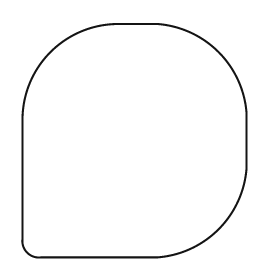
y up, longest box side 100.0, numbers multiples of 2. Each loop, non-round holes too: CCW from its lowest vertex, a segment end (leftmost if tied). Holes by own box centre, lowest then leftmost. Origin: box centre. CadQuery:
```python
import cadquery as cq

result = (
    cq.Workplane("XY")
    .moveTo(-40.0, -50.0)
    .lineTo(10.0, -50.0)
    .threePointArc((36.0, -38.0), (48.0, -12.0))
    .lineTo(48.0, 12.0)
    .threePointArc((36.0, 38.0), (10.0, 50.0))
    .lineTo(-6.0, 50.0)
    .threePointArc((-36.0, 38.0), (-48.0, 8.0))
    .lineTo(-48.0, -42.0)
    .threePointArc((-46.0, -48.0), (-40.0, -50.0))
    .close()
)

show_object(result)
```